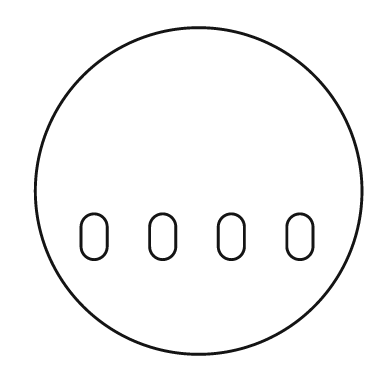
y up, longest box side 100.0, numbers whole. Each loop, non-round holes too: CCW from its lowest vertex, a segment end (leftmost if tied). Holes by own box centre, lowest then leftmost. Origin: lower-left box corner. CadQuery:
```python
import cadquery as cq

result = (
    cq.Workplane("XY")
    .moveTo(50.0, 50.0)
    .circle(50.0)
    .moveTo(14.0, 33.0)
    .threePointArc((18.0, 29.0), (22.0, 33.0))
    .lineTo(22.0, 39.0)
    .threePointArc((18.0, 43.0), (14.0, 39.0))
    .close()
    .moveTo(35.0, 33.0)
    .threePointArc((39.0, 29.0), (43.0, 33.0))
    .lineTo(43.0, 39.0)
    .threePointArc((39.0, 43.0), (35.0, 39.0))
    .close()
    .moveTo(56.0, 33.0)
    .threePointArc((60.0, 29.0), (64.0, 33.0))
    .lineTo(64.0, 39.0)
    .threePointArc((60.0, 43.0), (56.0, 39.0))
    .close()
    .moveTo(77.0, 33.0)
    .threePointArc((81.0, 29.0), (85.0, 33.0))
    .lineTo(85.0, 39.0)
    .threePointArc((81.0, 43.0), (77.0, 39.0))
    .close()
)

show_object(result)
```